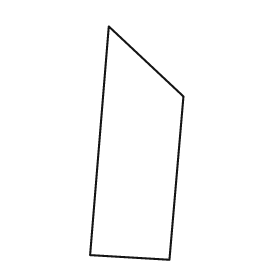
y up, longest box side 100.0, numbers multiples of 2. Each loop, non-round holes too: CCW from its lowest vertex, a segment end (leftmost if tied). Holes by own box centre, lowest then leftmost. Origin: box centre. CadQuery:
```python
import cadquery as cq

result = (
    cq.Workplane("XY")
    .moveTo(14.0, -50.0)
    .lineTo(20.0, 20.0)
    .lineTo(-12.0, 50.0)
    .lineTo(-20.0, -48.0)
    .close()
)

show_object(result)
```